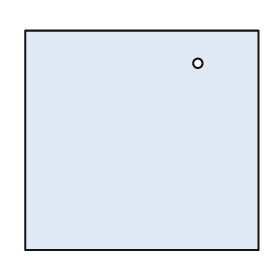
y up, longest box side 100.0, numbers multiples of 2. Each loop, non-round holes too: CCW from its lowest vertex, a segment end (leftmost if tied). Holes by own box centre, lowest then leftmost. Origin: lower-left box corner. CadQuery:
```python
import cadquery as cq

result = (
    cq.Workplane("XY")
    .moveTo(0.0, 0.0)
    .lineTo(100.0, 0.0)
    .lineTo(100.0, 94.0)
    .lineTo(0.0, 94.0)
    .close()
    .moveTo(74.0, 80.0)
    .circle(2.0)
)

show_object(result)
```